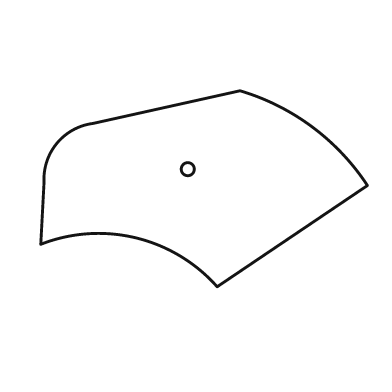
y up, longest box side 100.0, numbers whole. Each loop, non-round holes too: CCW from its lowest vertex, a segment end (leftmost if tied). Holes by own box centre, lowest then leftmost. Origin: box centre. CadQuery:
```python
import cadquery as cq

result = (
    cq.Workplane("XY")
    .moveTo(4.0, -30.0)
    .lineTo(50.0, 1.0)
    .threePointArc((33.0, 19.0), (11.0, 30.0))
    .lineTo(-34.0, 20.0)
    .threePointArc((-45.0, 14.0), (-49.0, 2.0))
    .lineTo(-50.0, -17.0)
    .threePointArc((-21.0, -15.0), (4.0, -30.0))
    .close()
    .moveTo(-5.0, 6.0)
    .circle(2.0)
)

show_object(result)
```